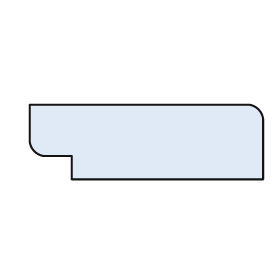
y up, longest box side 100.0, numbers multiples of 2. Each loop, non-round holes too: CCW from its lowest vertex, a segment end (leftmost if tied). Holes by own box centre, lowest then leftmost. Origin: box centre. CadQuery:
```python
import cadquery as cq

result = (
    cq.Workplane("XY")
    .moveTo(-32.0, -16.0)
    .lineTo(50.0, -16.0)
    .lineTo(50.0, 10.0)
    .threePointArc((48.0, 14.0), (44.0, 16.0))
    .lineTo(-50.0, 16.0)
    .lineTo(-50.0, 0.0)
    .threePointArc((-48.0, -4.0), (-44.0, -6.0))
    .lineTo(-32.0, -6.0)
    .close()
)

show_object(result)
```